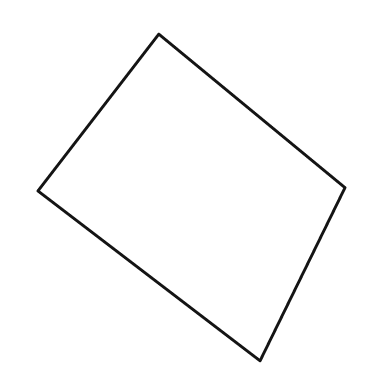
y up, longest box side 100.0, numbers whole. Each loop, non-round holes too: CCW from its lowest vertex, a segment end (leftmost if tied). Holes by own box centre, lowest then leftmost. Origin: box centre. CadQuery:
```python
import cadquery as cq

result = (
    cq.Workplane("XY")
    .moveTo(21.0, -50.0)
    .lineTo(47.0, 3.0)
    .lineTo(-10.0, 50.0)
    .lineTo(-47.0, 2.0)
    .close()
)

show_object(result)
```